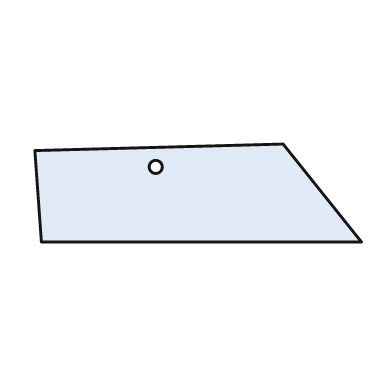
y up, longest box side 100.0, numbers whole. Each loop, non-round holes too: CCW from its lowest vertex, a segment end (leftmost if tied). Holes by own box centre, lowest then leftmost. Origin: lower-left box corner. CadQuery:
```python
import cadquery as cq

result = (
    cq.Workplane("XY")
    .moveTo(2.0, 0.0)
    .lineTo(100.0, 0.0)
    .lineTo(76.0, 30.0)
    .lineTo(0.0, 28.0)
    .close()
    .moveTo(37.0, 23.0)
    .circle(2.0)
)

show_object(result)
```